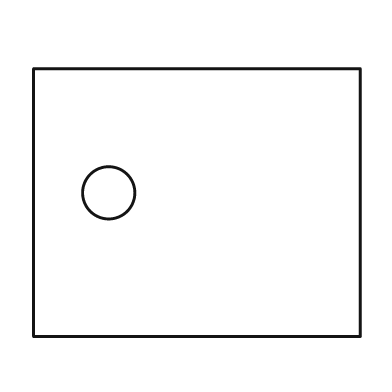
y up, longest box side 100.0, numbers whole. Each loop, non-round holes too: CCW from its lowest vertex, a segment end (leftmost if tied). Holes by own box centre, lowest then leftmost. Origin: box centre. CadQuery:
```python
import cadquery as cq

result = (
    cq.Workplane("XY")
    .moveTo(-50.0, -41.0)
    .lineTo(50.0, -41.0)
    .lineTo(50.0, 41.0)
    .lineTo(-50.0, 41.0)
    .close()
    .moveTo(-27.0, 3.0)
    .circle(8.0)
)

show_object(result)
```